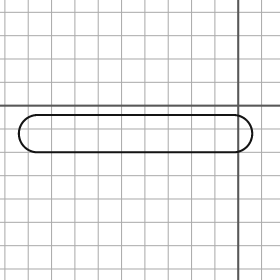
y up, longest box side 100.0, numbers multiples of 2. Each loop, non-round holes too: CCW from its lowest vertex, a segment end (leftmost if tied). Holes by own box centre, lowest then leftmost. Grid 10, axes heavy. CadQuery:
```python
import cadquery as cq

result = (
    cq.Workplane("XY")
    .moveTo(-86.0, -20.0)
    .lineTo(-2.0, -20.0)
    .threePointArc((6.0, -12.0), (-2.0, -4.0))
    .lineTo(-86.0, -4.0)
    .threePointArc((-94.0, -12.0), (-86.0, -20.0))
    .close()
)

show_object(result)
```